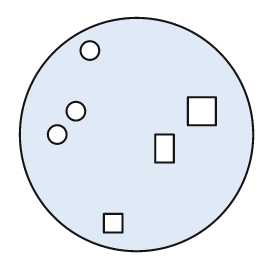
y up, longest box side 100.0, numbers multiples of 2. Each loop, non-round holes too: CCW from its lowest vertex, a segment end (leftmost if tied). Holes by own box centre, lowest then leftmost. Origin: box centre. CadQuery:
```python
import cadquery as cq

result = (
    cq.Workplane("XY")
    .moveTo(0.0, 0.0)
    .circle(50.0)
    .moveTo(-14.0, -42.0)
    .lineTo(-6.0, -42.0)
    .lineTo(-6.0, -34.0)
    .lineTo(-14.0, -34.0)
    .close()
    .moveTo(8.0, -12.0)
    .lineTo(16.0, -12.0)
    .lineTo(16.0, 0.0)
    .lineTo(8.0, 0.0)
    .close()
    .moveTo(-34.0, 0.0)
    .circle(4.0)
    .moveTo(-26.0, 10.0)
    .circle(4.0)
    .moveTo(22.0, 4.0)
    .lineTo(34.0, 4.0)
    .lineTo(34.0, 16.0)
    .lineTo(22.0, 16.0)
    .close()
    .moveTo(-20.0, 36.0)
    .circle(4.0)
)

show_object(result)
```